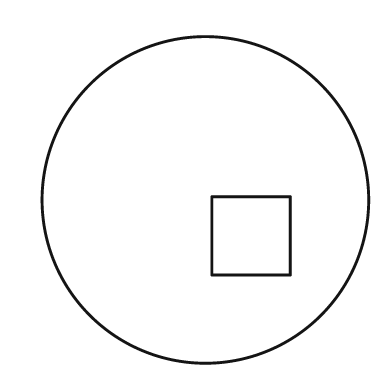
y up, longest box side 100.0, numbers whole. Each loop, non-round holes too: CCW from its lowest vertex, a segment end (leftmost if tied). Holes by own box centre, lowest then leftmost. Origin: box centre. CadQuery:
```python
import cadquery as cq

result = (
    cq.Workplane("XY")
    .moveTo(0.0, 0.0)
    .circle(50.0)
    .moveTo(2.0, -23.0)
    .lineTo(26.0, -23.0)
    .lineTo(26.0, 1.0)
    .lineTo(2.0, 1.0)
    .close()
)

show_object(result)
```